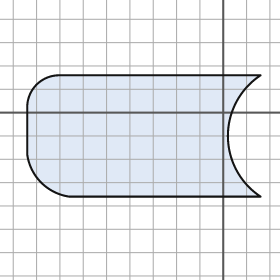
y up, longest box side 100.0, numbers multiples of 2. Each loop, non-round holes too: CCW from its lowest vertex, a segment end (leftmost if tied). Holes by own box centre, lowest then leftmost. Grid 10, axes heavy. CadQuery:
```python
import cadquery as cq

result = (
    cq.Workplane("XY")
    .moveTo(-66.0, -36.0)
    .lineTo(16.0, -36.0)
    .threePointArc((2.0, -10.0), (16.0, 16.0))
    .lineTo(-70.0, 16.0)
    .threePointArc((-80.0, 12.0), (-84.0, 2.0))
    .lineTo(-84.0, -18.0)
    .threePointArc((-78.0, -30.0), (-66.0, -36.0))
    .close()
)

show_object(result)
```